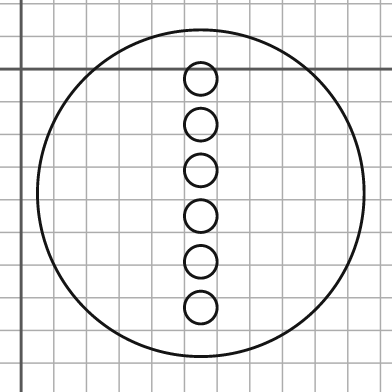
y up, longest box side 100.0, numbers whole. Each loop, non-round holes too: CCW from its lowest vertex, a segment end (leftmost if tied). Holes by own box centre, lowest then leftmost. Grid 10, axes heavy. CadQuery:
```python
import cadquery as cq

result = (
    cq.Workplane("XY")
    .moveTo(55.0, -38.0)
    .circle(50.0)
    .moveTo(55.0, -73.0)
    .circle(5.0)
    .moveTo(55.0, -59.0)
    .circle(5.0)
    .moveTo(55.0, -45.0)
    .circle(5.0)
    .moveTo(55.0, -31.0)
    .circle(5.0)
    .moveTo(55.0, -17.0)
    .circle(5.0)
    .moveTo(55.0, -3.0)
    .circle(5.0)
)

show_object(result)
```